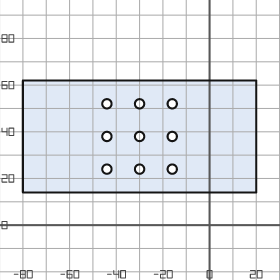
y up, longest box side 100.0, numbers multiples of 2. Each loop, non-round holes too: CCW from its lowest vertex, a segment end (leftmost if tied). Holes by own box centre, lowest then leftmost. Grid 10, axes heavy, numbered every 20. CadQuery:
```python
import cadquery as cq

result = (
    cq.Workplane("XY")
    .moveTo(-80.0, 14.0)
    .lineTo(20.0, 14.0)
    .lineTo(20.0, 62.0)
    .lineTo(-80.0, 62.0)
    .close()
    .moveTo(-44.0, 24.0)
    .circle(2.0)
    .moveTo(-30.0, 24.0)
    .circle(2.0)
    .moveTo(-16.0, 24.0)
    .circle(2.0)
    .moveTo(-44.0, 38.0)
    .circle(2.0)
    .moveTo(-30.0, 38.0)
    .circle(2.0)
    .moveTo(-16.0, 38.0)
    .circle(2.0)
    .moveTo(-44.0, 52.0)
    .circle(2.0)
    .moveTo(-30.0, 52.0)
    .circle(2.0)
    .moveTo(-16.0, 52.0)
    .circle(2.0)
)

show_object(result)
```